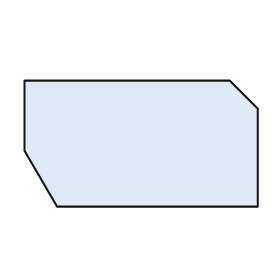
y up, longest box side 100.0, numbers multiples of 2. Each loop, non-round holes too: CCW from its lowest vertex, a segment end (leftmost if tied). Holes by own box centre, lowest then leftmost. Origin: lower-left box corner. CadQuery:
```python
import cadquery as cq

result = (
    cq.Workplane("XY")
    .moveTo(14.0, 0.0)
    .lineTo(100.0, 0.0)
    .lineTo(100.0, 42.0)
    .lineTo(88.0, 54.0)
    .lineTo(0.0, 54.0)
    .lineTo(0.0, 24.0)
    .close()
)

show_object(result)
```